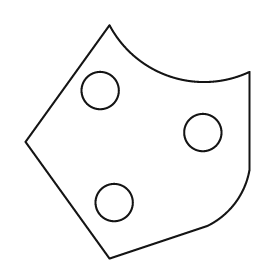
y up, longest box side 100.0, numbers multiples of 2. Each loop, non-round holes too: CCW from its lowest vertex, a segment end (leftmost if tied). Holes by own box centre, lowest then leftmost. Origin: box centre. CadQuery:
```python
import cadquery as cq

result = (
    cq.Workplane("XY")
    .moveTo(-12.0, -50.0)
    .lineTo(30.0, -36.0)
    .threePointArc((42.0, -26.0), (48.0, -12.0))
    .lineTo(48.0, 30.0)
    .threePointArc((14.0, 28.0), (-12.0, 50.0))
    .lineTo(-48.0, 0.0)
    .close()
    .moveTo(-10.0, -26.0)
    .circle(8.0)
    .moveTo(28.0, 4.0)
    .circle(8.0)
    .moveTo(-16.0, 22.0)
    .circle(8.0)
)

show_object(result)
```